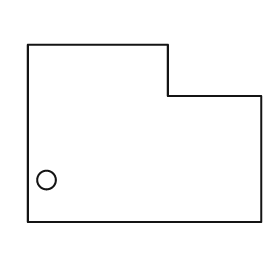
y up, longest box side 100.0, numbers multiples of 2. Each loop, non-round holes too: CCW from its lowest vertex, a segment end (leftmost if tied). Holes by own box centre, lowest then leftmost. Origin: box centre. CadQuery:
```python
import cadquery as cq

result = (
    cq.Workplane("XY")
    .moveTo(-50.0, -38.0)
    .lineTo(50.0, -38.0)
    .lineTo(50.0, 16.0)
    .lineTo(10.0, 16.0)
    .lineTo(10.0, 38.0)
    .lineTo(-50.0, 38.0)
    .close()
    .moveTo(-42.0, -20.0)
    .circle(4.0)
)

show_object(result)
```